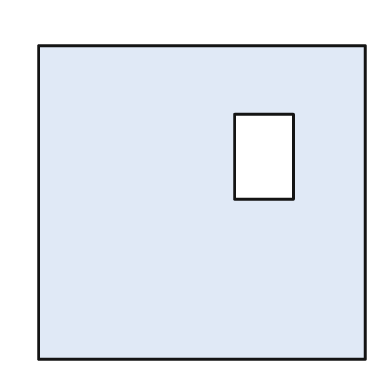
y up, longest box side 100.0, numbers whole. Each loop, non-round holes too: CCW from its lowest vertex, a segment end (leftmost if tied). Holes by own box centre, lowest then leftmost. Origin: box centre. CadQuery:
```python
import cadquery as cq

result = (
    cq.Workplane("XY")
    .moveTo(-50.0, -48.0)
    .lineTo(50.0, -48.0)
    .lineTo(50.0, 48.0)
    .lineTo(-50.0, 48.0)
    .close()
    .moveTo(10.0, 1.0)
    .lineTo(28.0, 1.0)
    .lineTo(28.0, 27.0)
    .lineTo(10.0, 27.0)
    .close()
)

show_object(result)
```